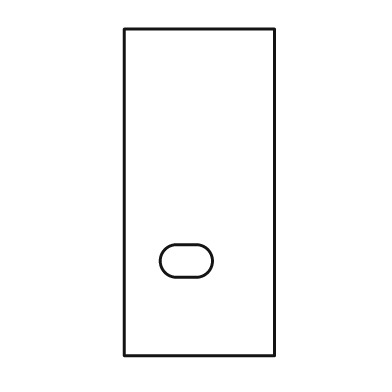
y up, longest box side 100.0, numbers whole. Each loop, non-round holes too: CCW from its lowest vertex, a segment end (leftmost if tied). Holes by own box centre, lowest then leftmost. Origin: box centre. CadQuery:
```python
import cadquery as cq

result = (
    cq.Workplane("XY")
    .moveTo(-23.0, -50.0)
    .lineTo(23.0, -50.0)
    .lineTo(23.0, 50.0)
    .lineTo(-23.0, 50.0)
    .close()
    .moveTo(-7.0, -26.0)
    .lineTo(-1.0, -26.0)
    .threePointArc((4.0, -21.0), (-1.0, -16.0))
    .lineTo(-7.0, -16.0)
    .threePointArc((-12.0, -21.0), (-7.0, -26.0))
    .close()
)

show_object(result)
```